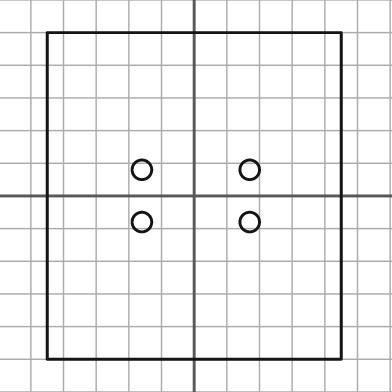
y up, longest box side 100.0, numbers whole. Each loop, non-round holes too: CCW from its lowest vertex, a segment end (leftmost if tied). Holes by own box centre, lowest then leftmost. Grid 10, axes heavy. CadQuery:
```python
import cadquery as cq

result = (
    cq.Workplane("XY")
    .moveTo(-45.0, -50.0)
    .lineTo(45.0, -50.0)
    .lineTo(45.0, 50.0)
    .lineTo(-45.0, 50.0)
    .close()
    .moveTo(-16.0, -8.0)
    .circle(3.0)
    .moveTo(17.0, -8.0)
    .circle(3.0)
    .moveTo(-16.0, 8.0)
    .circle(3.0)
    .moveTo(17.0, 8.0)
    .circle(3.0)
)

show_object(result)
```